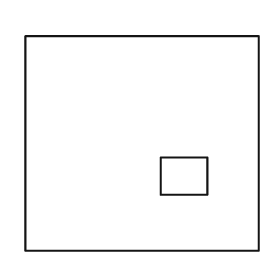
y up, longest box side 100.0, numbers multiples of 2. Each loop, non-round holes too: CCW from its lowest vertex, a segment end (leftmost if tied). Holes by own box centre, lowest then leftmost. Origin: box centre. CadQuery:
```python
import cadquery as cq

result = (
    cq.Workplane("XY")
    .moveTo(-50.0, -46.0)
    .lineTo(50.0, -46.0)
    .lineTo(50.0, 46.0)
    .lineTo(-50.0, 46.0)
    .close()
    .moveTo(8.0, -22.0)
    .lineTo(28.0, -22.0)
    .lineTo(28.0, -6.0)
    .lineTo(8.0, -6.0)
    .close()
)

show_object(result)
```